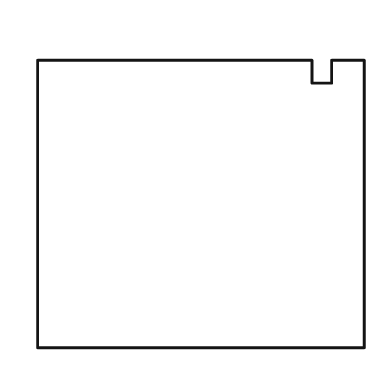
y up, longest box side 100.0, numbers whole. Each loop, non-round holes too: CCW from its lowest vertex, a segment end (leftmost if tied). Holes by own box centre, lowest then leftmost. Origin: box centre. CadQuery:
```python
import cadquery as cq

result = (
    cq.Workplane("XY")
    .moveTo(-50.0, -44.0)
    .lineTo(50.0, -44.0)
    .lineTo(50.0, 44.0)
    .lineTo(40.0, 44.0)
    .lineTo(40.0, 37.0)
    .lineTo(34.0, 37.0)
    .lineTo(34.0, 44.0)
    .lineTo(-50.0, 44.0)
    .close()
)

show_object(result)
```